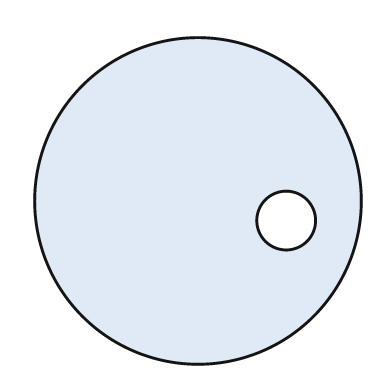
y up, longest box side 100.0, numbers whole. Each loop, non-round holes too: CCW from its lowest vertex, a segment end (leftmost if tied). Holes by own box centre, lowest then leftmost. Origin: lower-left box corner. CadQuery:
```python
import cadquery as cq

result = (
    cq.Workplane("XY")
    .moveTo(50.0, 50.0)
    .circle(50.0)
    .moveTo(77.0, 44.0)
    .circle(9.0)
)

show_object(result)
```